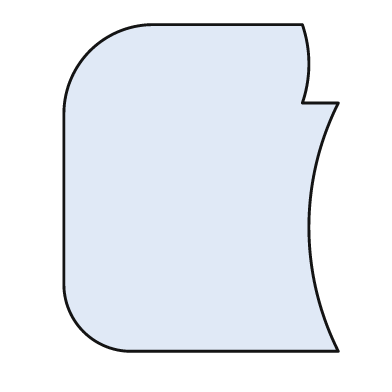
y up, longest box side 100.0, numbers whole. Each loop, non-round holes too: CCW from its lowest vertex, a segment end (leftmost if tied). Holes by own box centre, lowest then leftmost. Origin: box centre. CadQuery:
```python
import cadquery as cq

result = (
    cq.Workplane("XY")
    .moveTo(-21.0, -50.0)
    .lineTo(42.0, -50.0)
    .threePointArc((33.0, -12.0), (42.0, 26.0))
    .lineTo(31.0, 26.0)
    .threePointArc((33.0, 38.0), (31.0, 50.0))
    .lineTo(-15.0, 50.0)
    .threePointArc((-34.0, 42.0), (-42.0, 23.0))
    .lineTo(-42.0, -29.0)
    .threePointArc((-36.0, -44.0), (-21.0, -50.0))
    .close()
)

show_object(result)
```